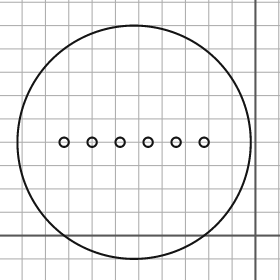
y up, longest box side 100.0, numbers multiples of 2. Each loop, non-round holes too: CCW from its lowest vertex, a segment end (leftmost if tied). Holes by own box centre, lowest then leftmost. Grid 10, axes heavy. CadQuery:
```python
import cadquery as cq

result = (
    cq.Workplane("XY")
    .moveTo(-52.0, 40.0)
    .circle(50.0)
    .moveTo(-82.0, 40.0)
    .circle(2.0)
    .moveTo(-70.0, 40.0)
    .circle(2.0)
    .moveTo(-58.0, 40.0)
    .circle(2.0)
    .moveTo(-46.0, 40.0)
    .circle(2.0)
    .moveTo(-34.0, 40.0)
    .circle(2.0)
    .moveTo(-22.0, 40.0)
    .circle(2.0)
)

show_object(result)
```